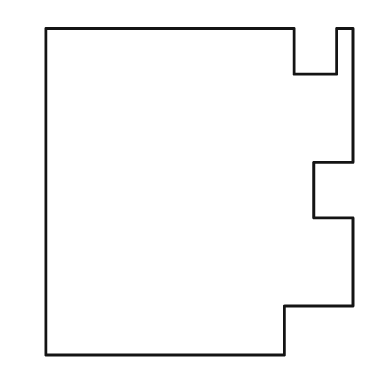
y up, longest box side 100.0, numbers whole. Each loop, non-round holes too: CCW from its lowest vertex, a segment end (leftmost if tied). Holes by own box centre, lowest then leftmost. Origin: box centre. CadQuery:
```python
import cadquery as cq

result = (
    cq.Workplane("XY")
    .moveTo(-47.0, -50.0)
    .lineTo(26.0, -50.0)
    .lineTo(26.0, -35.0)
    .lineTo(47.0, -35.0)
    .lineTo(47.0, -8.0)
    .lineTo(35.0, -8.0)
    .lineTo(35.0, 9.0)
    .lineTo(47.0, 9.0)
    .lineTo(47.0, 50.0)
    .lineTo(42.0, 50.0)
    .lineTo(42.0, 36.0)
    .lineTo(29.0, 36.0)
    .lineTo(29.0, 50.0)
    .lineTo(-47.0, 50.0)
    .close()
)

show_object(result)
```